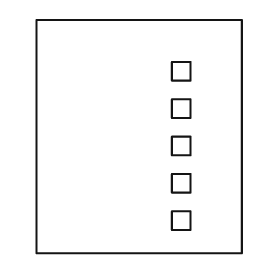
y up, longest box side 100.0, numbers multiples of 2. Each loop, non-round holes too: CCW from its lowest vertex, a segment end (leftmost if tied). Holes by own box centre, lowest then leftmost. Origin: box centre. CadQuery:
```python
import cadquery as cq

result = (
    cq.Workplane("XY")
    .moveTo(-44.0, -50.0)
    .lineTo(44.0, -50.0)
    .lineTo(44.0, 50.0)
    .lineTo(-44.0, 50.0)
    .close()
    .moveTo(14.0, -40.0)
    .lineTo(22.0, -40.0)
    .lineTo(22.0, -32.0)
    .lineTo(14.0, -32.0)
    .close()
    .moveTo(14.0, -24.0)
    .lineTo(22.0, -24.0)
    .lineTo(22.0, -16.0)
    .lineTo(14.0, -16.0)
    .close()
    .moveTo(14.0, -8.0)
    .lineTo(22.0, -8.0)
    .lineTo(22.0, 0.0)
    .lineTo(14.0, 0.0)
    .close()
    .moveTo(14.0, 8.0)
    .lineTo(22.0, 8.0)
    .lineTo(22.0, 16.0)
    .lineTo(14.0, 16.0)
    .close()
    .moveTo(14.0, 24.0)
    .lineTo(22.0, 24.0)
    .lineTo(22.0, 32.0)
    .lineTo(14.0, 32.0)
    .close()
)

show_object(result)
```